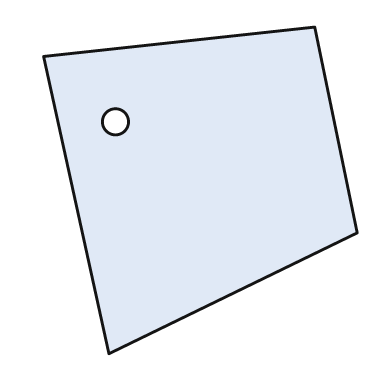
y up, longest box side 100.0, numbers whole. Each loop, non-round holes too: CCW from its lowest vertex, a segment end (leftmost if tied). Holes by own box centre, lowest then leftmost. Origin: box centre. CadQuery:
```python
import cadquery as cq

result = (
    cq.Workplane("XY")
    .moveTo(-28.0, -50.0)
    .lineTo(48.0, -13.0)
    .lineTo(35.0, 50.0)
    .lineTo(-48.0, 41.0)
    .close()
    .moveTo(-26.0, 21.0)
    .circle(4.0)
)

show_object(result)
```